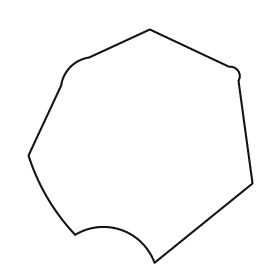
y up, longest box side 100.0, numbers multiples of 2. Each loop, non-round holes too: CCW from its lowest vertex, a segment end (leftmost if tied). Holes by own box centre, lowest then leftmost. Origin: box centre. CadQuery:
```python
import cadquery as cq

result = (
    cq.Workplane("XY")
    .moveTo(6.0, -50.0)
    .lineTo(48.0, -16.0)
    .lineTo(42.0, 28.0)
    .threePointArc((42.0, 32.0), (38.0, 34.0))
    .lineTo(4.0, 50.0)
    .lineTo(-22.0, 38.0)
    .threePointArc((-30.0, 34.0), (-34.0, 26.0))
    .lineTo(-48.0, -4.0)
    .threePointArc((-40.0, -22.0), (-28.0, -38.0))
    .threePointArc((-8.0, -36.0), (6.0, -50.0))
    .close()
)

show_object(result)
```